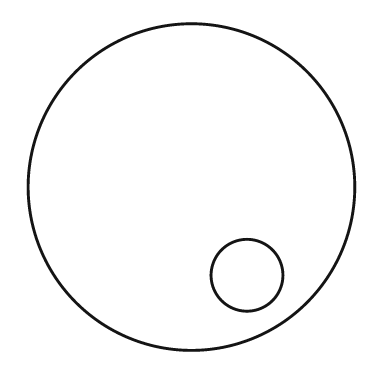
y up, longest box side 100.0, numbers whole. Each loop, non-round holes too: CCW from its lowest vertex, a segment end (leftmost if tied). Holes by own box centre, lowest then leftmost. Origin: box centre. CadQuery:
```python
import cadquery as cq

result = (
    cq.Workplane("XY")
    .moveTo(0.0, 0.0)
    .circle(50.0)
    .moveTo(17.0, -27.0)
    .circle(11.0)
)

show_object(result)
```